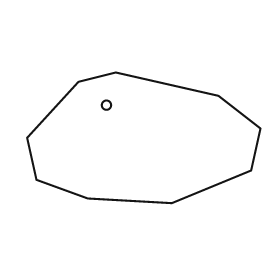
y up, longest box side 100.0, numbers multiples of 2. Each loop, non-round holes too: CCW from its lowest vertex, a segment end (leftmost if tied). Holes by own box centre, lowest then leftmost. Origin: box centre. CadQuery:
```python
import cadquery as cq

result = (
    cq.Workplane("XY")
    .moveTo(12.0, -28.0)
    .lineTo(46.0, -14.0)
    .lineTo(50.0, 4.0)
    .lineTo(32.0, 18.0)
    .lineTo(-12.0, 28.0)
    .lineTo(-28.0, 24.0)
    .lineTo(-50.0, 0.0)
    .lineTo(-46.0, -18.0)
    .lineTo(-24.0, -26.0)
    .close()
    .moveTo(-16.0, 14.0)
    .circle(2.0)
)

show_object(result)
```